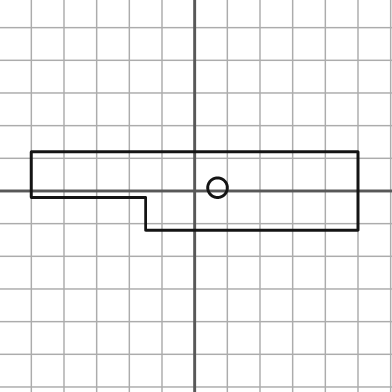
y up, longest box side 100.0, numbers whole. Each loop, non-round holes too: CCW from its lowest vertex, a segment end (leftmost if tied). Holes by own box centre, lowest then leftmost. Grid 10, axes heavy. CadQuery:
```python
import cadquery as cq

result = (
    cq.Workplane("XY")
    .moveTo(-15.0, -12.0)
    .lineTo(50.0, -12.0)
    .lineTo(50.0, 12.0)
    .lineTo(-50.0, 12.0)
    .lineTo(-50.0, -2.0)
    .lineTo(-15.0, -2.0)
    .close()
    .moveTo(7.0, 1.0)
    .circle(3.0)
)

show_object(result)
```